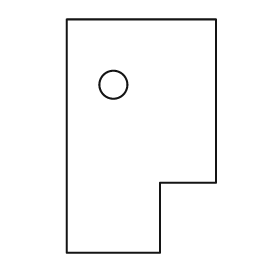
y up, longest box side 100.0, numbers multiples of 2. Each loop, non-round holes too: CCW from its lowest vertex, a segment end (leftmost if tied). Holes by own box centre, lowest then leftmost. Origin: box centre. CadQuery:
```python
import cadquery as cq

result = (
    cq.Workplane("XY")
    .moveTo(-32.0, -50.0)
    .lineTo(8.0, -50.0)
    .lineTo(8.0, -20.0)
    .lineTo(32.0, -20.0)
    .lineTo(32.0, 50.0)
    .lineTo(-32.0, 50.0)
    .close()
    .moveTo(-12.0, 22.0)
    .circle(6.0)
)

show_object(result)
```